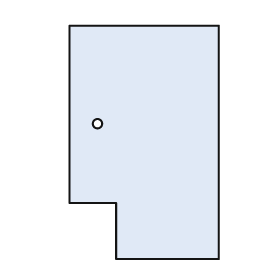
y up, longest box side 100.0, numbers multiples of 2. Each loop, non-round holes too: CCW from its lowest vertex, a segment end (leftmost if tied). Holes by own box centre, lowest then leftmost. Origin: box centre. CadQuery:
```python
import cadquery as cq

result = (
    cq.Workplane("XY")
    .moveTo(-12.0, -50.0)
    .lineTo(32.0, -50.0)
    .lineTo(32.0, 50.0)
    .lineTo(-32.0, 50.0)
    .lineTo(-32.0, -26.0)
    .lineTo(-12.0, -26.0)
    .close()
    .moveTo(-20.0, 8.0)
    .circle(2.0)
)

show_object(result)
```